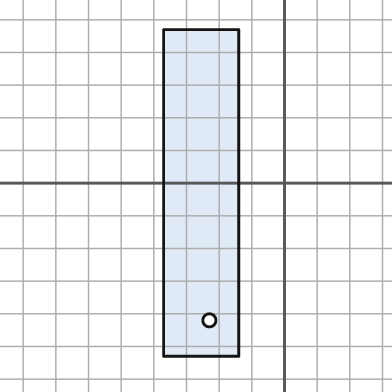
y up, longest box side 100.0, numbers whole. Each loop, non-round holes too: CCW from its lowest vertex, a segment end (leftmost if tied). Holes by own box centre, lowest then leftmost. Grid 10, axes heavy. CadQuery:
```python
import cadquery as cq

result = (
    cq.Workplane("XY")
    .moveTo(-37.0, -53.0)
    .lineTo(-14.0, -53.0)
    .lineTo(-14.0, 47.0)
    .lineTo(-37.0, 47.0)
    .close()
    .moveTo(-23.0, -42.0)
    .circle(2.0)
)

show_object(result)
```